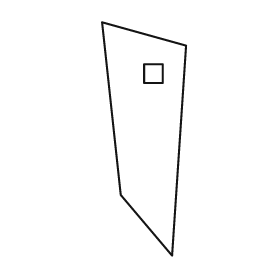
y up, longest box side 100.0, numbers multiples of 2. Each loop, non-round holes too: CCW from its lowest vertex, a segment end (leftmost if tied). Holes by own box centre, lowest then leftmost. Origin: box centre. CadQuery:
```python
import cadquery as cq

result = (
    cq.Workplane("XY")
    .moveTo(12.0, -50.0)
    .lineTo(18.0, 40.0)
    .lineTo(-18.0, 50.0)
    .lineTo(-10.0, -24.0)
    .close()
    .moveTo(0.0, 24.0)
    .lineTo(8.0, 24.0)
    .lineTo(8.0, 32.0)
    .lineTo(0.0, 32.0)
    .close()
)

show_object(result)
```